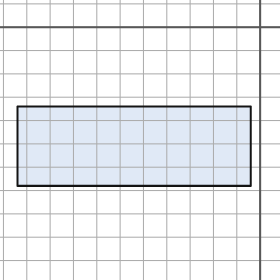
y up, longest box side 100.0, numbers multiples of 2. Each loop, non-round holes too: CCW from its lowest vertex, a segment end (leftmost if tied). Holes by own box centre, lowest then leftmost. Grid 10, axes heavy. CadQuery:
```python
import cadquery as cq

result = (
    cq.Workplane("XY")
    .moveTo(-104.0, -68.0)
    .lineTo(-4.0, -68.0)
    .lineTo(-4.0, -34.0)
    .lineTo(-104.0, -34.0)
    .close()
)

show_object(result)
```